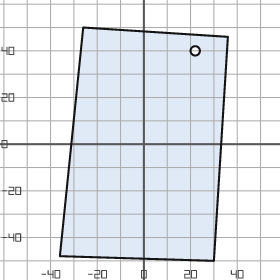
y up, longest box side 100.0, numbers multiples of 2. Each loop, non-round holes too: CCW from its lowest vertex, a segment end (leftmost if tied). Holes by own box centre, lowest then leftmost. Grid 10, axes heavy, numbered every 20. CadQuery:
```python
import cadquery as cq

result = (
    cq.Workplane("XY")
    .moveTo(30.0, -50.0)
    .lineTo(36.0, 46.0)
    .lineTo(-26.0, 50.0)
    .lineTo(-36.0, -48.0)
    .close()
    .moveTo(22.0, 40.0)
    .circle(2.0)
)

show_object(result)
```